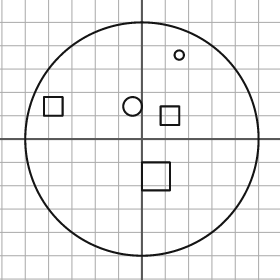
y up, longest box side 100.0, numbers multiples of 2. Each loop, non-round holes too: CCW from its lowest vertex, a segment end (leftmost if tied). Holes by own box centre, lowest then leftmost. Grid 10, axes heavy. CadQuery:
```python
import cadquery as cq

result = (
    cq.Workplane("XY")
    .moveTo(0.0, 0.0)
    .circle(50.0)
    .moveTo(0.0, -22.0)
    .lineTo(12.0, -22.0)
    .lineTo(12.0, -10.0)
    .lineTo(0.0, -10.0)
    .close()
    .moveTo(8.0, 6.0)
    .lineTo(16.0, 6.0)
    .lineTo(16.0, 14.0)
    .lineTo(8.0, 14.0)
    .close()
    .moveTo(-42.0, 10.0)
    .lineTo(-34.0, 10.0)
    .lineTo(-34.0, 18.0)
    .lineTo(-42.0, 18.0)
    .close()
    .moveTo(-4.0, 14.0)
    .circle(4.0)
    .moveTo(16.0, 36.0)
    .circle(2.0)
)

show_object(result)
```